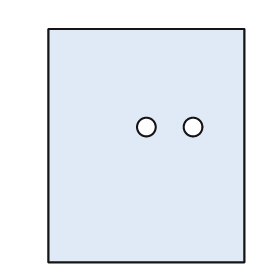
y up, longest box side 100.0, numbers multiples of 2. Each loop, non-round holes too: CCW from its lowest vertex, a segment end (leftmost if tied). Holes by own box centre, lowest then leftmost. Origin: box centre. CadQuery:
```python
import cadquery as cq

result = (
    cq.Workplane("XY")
    .moveTo(-42.0, -50.0)
    .lineTo(42.0, -50.0)
    .lineTo(42.0, 50.0)
    .lineTo(-42.0, 50.0)
    .close()
    .moveTo(0.0, 8.0)
    .circle(4.0)
    .moveTo(20.0, 8.0)
    .circle(4.0)
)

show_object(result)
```